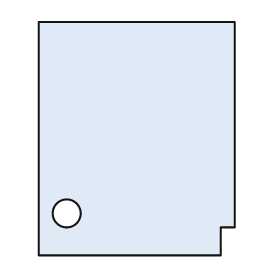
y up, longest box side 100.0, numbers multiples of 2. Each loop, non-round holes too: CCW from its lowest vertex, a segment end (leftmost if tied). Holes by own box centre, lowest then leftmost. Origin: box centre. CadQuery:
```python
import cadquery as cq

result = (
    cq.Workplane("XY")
    .moveTo(-42.0, -50.0)
    .lineTo(36.0, -50.0)
    .lineTo(36.0, -38.0)
    .lineTo(42.0, -38.0)
    .lineTo(42.0, 50.0)
    .lineTo(-42.0, 50.0)
    .close()
    .moveTo(-30.0, -32.0)
    .circle(6.0)
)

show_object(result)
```